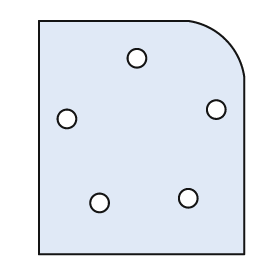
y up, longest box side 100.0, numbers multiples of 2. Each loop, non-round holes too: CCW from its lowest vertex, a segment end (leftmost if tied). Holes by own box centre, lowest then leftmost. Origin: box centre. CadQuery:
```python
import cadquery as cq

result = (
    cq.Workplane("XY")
    .moveTo(-44.0, -50.0)
    .lineTo(44.0, -50.0)
    .lineTo(44.0, 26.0)
    .threePointArc((36.0, 42.0), (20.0, 50.0))
    .lineTo(-44.0, 50.0)
    .close()
    .moveTo(-18.0, -28.0)
    .circle(4.0)
    .moveTo(20.0, -26.0)
    .circle(4.0)
    .moveTo(-32.0, 8.0)
    .circle(4.0)
    .moveTo(32.0, 12.0)
    .circle(4.0)
    .moveTo(-2.0, 34.0)
    .circle(4.0)
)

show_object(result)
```